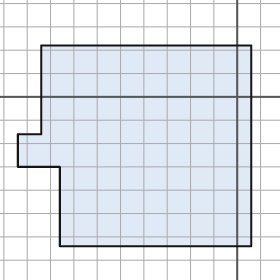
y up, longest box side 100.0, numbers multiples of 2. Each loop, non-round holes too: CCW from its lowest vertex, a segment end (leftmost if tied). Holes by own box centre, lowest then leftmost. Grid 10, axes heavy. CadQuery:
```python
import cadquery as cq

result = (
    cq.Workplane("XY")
    .moveTo(-76.0, -64.0)
    .lineTo(6.0, -64.0)
    .lineTo(6.0, 22.0)
    .lineTo(-84.0, 22.0)
    .lineTo(-84.0, -16.0)
    .lineTo(-94.0, -16.0)
    .lineTo(-94.0, -30.0)
    .lineTo(-76.0, -30.0)
    .close()
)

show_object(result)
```